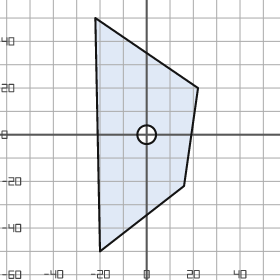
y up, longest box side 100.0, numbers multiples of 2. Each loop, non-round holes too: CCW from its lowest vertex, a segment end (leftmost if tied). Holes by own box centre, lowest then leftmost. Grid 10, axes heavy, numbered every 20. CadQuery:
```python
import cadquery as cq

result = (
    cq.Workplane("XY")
    .moveTo(-20.0, -50.0)
    .lineTo(16.0, -22.0)
    .lineTo(22.0, 20.0)
    .lineTo(-22.0, 50.0)
    .close()
    .moveTo(0.0, 0.0)
    .circle(4.0)
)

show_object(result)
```